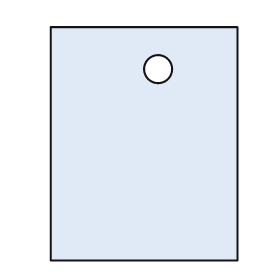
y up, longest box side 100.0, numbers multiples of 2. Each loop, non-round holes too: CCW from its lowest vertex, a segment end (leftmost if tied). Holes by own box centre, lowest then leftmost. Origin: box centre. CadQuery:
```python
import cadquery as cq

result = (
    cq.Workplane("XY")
    .moveTo(-40.0, -50.0)
    .lineTo(40.0, -50.0)
    .lineTo(40.0, 50.0)
    .lineTo(-40.0, 50.0)
    .close()
    .moveTo(6.0, 32.0)
    .circle(6.0)
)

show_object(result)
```